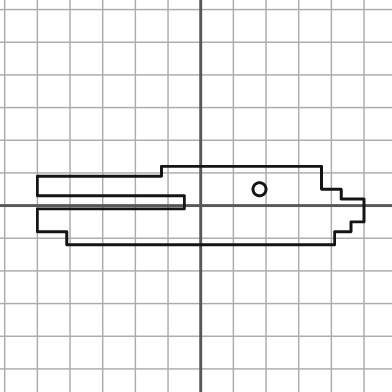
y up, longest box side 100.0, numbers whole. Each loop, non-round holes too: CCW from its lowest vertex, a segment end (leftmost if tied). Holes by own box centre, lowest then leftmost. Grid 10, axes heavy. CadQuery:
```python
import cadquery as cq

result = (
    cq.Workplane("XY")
    .moveTo(-41.0, -12.0)
    .lineTo(41.0, -12.0)
    .lineTo(41.0, -8.0)
    .lineTo(46.0, -8.0)
    .lineTo(46.0, -5.0)
    .lineTo(50.0, -5.0)
    .lineTo(50.0, 2.0)
    .lineTo(43.0, 2.0)
    .lineTo(43.0, 5.0)
    .lineTo(37.0, 5.0)
    .lineTo(37.0, 12.0)
    .lineTo(-12.0, 12.0)
    .lineTo(-12.0, 9.0)
    .lineTo(-50.0, 9.0)
    .lineTo(-50.0, 3.0)
    .lineTo(-5.0, 3.0)
    .lineTo(-5.0, -1.0)
    .lineTo(-50.0, -1.0)
    .lineTo(-50.0, -8.0)
    .lineTo(-41.0, -8.0)
    .close()
    .moveTo(18.0, 5.0)
    .circle(2.0)
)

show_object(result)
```